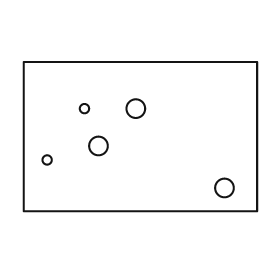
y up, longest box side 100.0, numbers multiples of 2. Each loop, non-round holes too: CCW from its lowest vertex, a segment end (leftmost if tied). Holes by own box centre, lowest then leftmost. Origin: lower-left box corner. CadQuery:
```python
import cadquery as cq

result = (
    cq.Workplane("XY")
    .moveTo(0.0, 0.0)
    .lineTo(100.0, 0.0)
    .lineTo(100.0, 64.0)
    .lineTo(0.0, 64.0)
    .close()
    .moveTo(86.0, 10.0)
    .circle(4.0)
    .moveTo(10.0, 22.0)
    .circle(2.0)
    .moveTo(32.0, 28.0)
    .circle(4.0)
    .moveTo(26.0, 44.0)
    .circle(2.0)
    .moveTo(48.0, 44.0)
    .circle(4.0)
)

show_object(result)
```